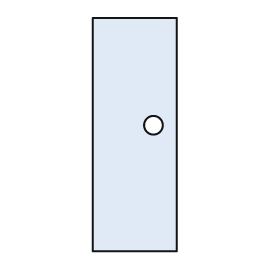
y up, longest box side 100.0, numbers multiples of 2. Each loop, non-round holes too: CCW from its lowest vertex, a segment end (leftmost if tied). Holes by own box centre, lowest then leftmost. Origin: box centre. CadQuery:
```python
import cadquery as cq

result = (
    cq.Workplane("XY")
    .moveTo(-18.0, -50.0)
    .lineTo(18.0, -50.0)
    .lineTo(18.0, 50.0)
    .lineTo(-18.0, 50.0)
    .close()
    .moveTo(8.0, 4.0)
    .circle(4.0)
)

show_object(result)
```